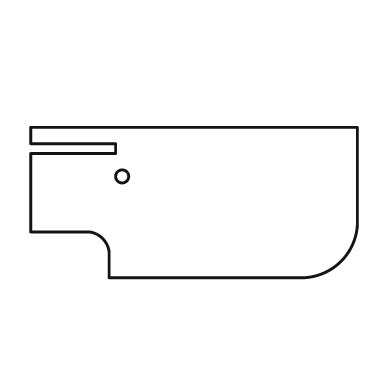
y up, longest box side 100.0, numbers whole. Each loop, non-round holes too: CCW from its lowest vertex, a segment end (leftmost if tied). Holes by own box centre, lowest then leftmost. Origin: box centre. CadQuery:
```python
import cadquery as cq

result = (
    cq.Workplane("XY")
    .moveTo(-26.0, -23.0)
    .lineTo(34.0, -23.0)
    .threePointArc((45.0, -18.0), (50.0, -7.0))
    .lineTo(50.0, 23.0)
    .lineTo(-50.0, 23.0)
    .lineTo(-50.0, 18.0)
    .lineTo(-24.0, 18.0)
    .lineTo(-24.0, 15.0)
    .lineTo(-50.0, 15.0)
    .lineTo(-50.0, -9.0)
    .lineTo(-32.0, -9.0)
    .threePointArc((-28.0, -11.0), (-26.0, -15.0))
    .close()
    .moveTo(-22.0, 8.0)
    .circle(2.0)
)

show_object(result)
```